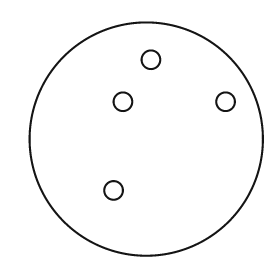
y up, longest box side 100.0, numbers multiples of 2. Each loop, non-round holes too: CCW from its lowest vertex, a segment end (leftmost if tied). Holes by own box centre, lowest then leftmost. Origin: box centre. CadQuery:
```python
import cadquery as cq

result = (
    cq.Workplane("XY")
    .moveTo(0.0, 0.0)
    .circle(50.0)
    .moveTo(-14.0, -22.0)
    .circle(4.0)
    .moveTo(-10.0, 16.0)
    .circle(4.0)
    .moveTo(34.0, 16.0)
    .circle(4.0)
    .moveTo(2.0, 34.0)
    .circle(4.0)
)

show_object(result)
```